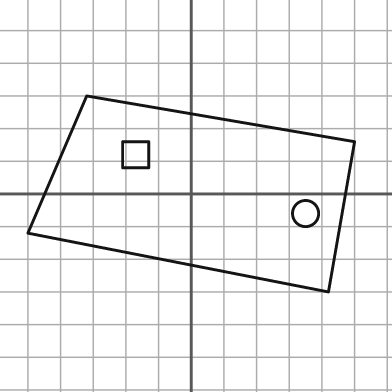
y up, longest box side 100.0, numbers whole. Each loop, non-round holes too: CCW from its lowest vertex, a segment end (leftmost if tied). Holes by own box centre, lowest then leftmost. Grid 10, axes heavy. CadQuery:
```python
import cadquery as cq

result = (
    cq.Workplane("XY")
    .moveTo(42.0, -30.0)
    .lineTo(50.0, 16.0)
    .lineTo(-32.0, 30.0)
    .lineTo(-50.0, -12.0)
    .close()
    .moveTo(35.0, -6.0)
    .circle(4.0)
    .moveTo(-21.0, 8.0)
    .lineTo(-13.0, 8.0)
    .lineTo(-13.0, 16.0)
    .lineTo(-21.0, 16.0)
    .close()
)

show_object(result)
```